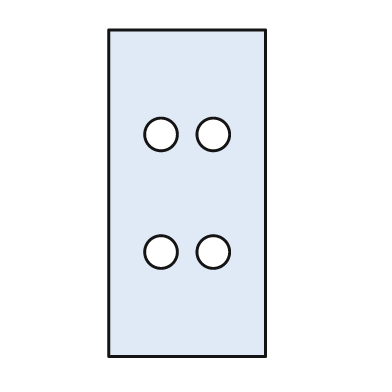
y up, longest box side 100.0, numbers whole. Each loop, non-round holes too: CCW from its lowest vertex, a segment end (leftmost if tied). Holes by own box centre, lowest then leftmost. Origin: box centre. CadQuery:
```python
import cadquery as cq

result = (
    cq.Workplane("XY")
    .moveTo(-24.0, -50.0)
    .lineTo(24.0, -50.0)
    .lineTo(24.0, 50.0)
    .lineTo(-24.0, 50.0)
    .close()
    .moveTo(-8.0, -18.0)
    .circle(5.0)
    .moveTo(8.0, -18.0)
    .circle(5.0)
    .moveTo(-8.0, 18.0)
    .circle(5.0)
    .moveTo(8.0, 18.0)
    .circle(5.0)
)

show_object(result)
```